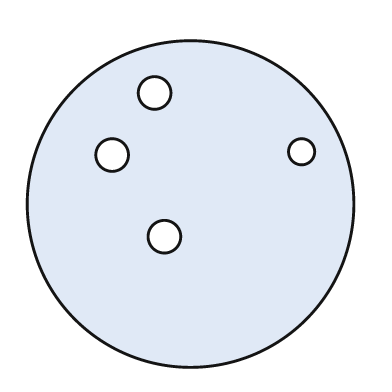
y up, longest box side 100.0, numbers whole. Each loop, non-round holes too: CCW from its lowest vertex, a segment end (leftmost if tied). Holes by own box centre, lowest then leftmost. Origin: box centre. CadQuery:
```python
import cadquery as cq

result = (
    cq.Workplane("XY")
    .moveTo(0.0, 0.0)
    .circle(50.0)
    .moveTo(-8.0, -10.0)
    .circle(5.0)
    .moveTo(-24.0, 15.0)
    .circle(5.0)
    .moveTo(34.0, 16.0)
    .circle(4.0)
    .moveTo(-11.0, 34.0)
    .circle(5.0)
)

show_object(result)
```